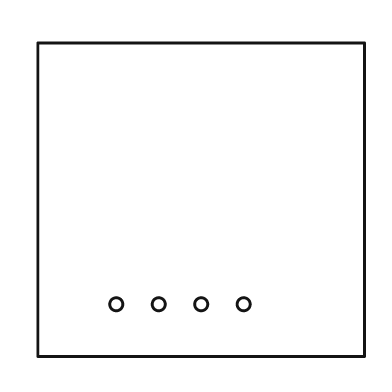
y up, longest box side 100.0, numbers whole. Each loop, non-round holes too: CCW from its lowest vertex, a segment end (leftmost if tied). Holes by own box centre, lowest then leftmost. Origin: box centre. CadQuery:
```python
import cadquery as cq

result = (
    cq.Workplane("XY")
    .moveTo(-50.0, -48.0)
    .lineTo(50.0, -48.0)
    .lineTo(50.0, 48.0)
    .lineTo(-50.0, 48.0)
    .close()
    .moveTo(-26.0, -32.0)
    .circle(2.0)
    .moveTo(-13.0, -32.0)
    .circle(2.0)
    .moveTo(0.0, -32.0)
    .circle(2.0)
    .moveTo(13.0, -32.0)
    .circle(2.0)
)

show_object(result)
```